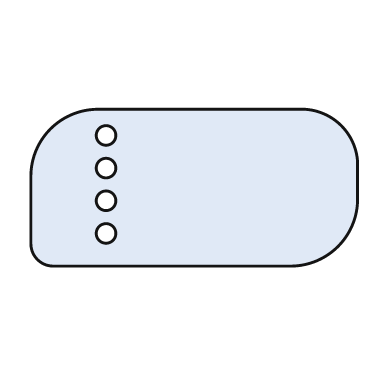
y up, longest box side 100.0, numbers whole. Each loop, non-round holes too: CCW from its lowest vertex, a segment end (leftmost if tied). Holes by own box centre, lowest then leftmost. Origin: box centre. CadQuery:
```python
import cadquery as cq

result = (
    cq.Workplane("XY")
    .moveTo(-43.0, -24.0)
    .lineTo(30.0, -24.0)
    .threePointArc((44.0, -18.0), (50.0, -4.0))
    .lineTo(50.0, 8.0)
    .threePointArc((45.0, 19.0), (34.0, 24.0))
    .lineTo(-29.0, 24.0)
    .threePointArc((-44.0, 18.0), (-50.0, 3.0))
    .lineTo(-50.0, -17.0)
    .threePointArc((-48.0, -22.0), (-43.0, -24.0))
    .close()
    .moveTo(-27.0, -14.0)
    .circle(3.0)
    .moveTo(-27.0, -4.0)
    .circle(3.0)
    .moveTo(-27.0, 6.0)
    .circle(3.0)
    .moveTo(-27.0, 16.0)
    .circle(3.0)
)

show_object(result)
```